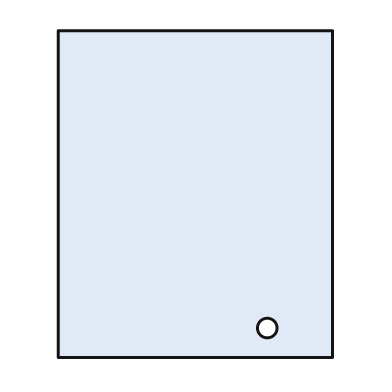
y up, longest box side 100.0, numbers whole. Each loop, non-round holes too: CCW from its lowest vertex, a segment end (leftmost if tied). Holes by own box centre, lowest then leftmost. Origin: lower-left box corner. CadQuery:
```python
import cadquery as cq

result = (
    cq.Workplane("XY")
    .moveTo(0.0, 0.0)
    .lineTo(84.0, 0.0)
    .lineTo(84.0, 100.0)
    .lineTo(0.0, 100.0)
    .close()
    .moveTo(64.0, 9.0)
    .circle(3.0)
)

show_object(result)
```